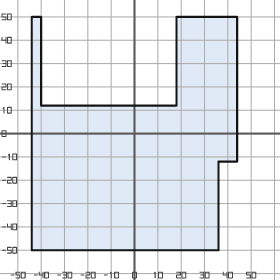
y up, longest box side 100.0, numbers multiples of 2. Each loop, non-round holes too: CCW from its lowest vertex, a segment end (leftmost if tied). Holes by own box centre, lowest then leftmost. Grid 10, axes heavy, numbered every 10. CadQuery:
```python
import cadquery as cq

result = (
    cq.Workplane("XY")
    .moveTo(-44.0, -50.0)
    .lineTo(36.0, -50.0)
    .lineTo(36.0, -12.0)
    .lineTo(44.0, -12.0)
    .lineTo(44.0, 50.0)
    .lineTo(18.0, 50.0)
    .lineTo(18.0, 12.0)
    .lineTo(-40.0, 12.0)
    .lineTo(-40.0, 50.0)
    .lineTo(-44.0, 50.0)
    .close()
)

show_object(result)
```